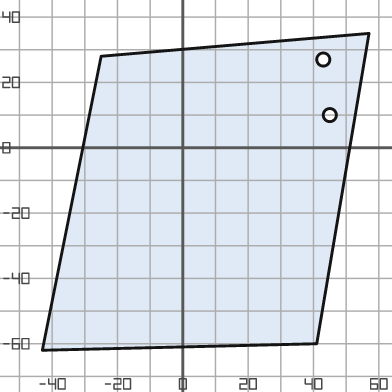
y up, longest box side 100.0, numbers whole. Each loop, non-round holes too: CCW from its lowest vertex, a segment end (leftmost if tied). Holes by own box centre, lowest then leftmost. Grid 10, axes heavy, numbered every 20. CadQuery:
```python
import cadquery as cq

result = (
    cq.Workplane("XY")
    .moveTo(-43.0, -62.0)
    .lineTo(41.0, -60.0)
    .lineTo(57.0, 35.0)
    .lineTo(-25.0, 28.0)
    .close()
    .moveTo(45.0, 10.0)
    .circle(2.0)
    .moveTo(43.0, 27.0)
    .circle(2.0)
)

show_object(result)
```